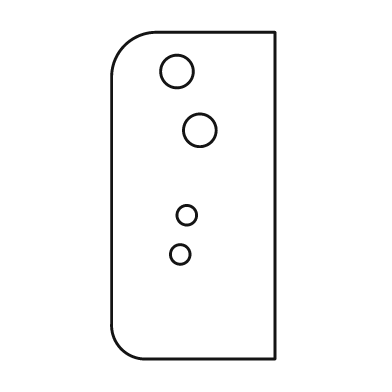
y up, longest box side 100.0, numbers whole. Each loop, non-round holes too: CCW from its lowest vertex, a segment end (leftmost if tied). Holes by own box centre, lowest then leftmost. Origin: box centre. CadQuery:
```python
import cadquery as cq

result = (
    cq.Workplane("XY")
    .moveTo(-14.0, -50.0)
    .lineTo(25.0, -50.0)
    .lineTo(25.0, 50.0)
    .lineTo(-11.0, 50.0)
    .threePointArc((-21.0, 46.0), (-25.0, 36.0))
    .lineTo(-25.0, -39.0)
    .threePointArc((-22.0, -47.0), (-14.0, -50.0))
    .close()
    .moveTo(-4.0, -18.0)
    .circle(3.0)
    .moveTo(-2.0, -6.0)
    .circle(3.0)
    .moveTo(2.0, 20.0)
    .circle(5.0)
    .moveTo(-5.0, 38.0)
    .circle(5.0)
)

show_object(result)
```